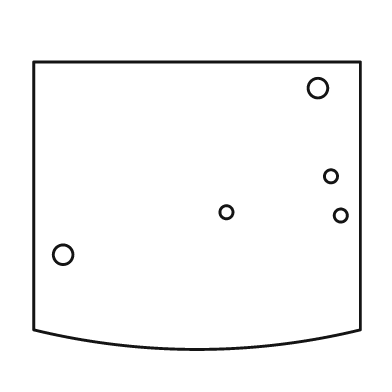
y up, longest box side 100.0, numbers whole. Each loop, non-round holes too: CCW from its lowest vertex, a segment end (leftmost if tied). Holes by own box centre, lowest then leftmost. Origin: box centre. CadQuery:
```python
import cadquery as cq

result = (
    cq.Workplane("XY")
    .moveTo(-50.0, -38.0)
    .threePointArc((0.0, -44.0), (50.0, -38.0))
    .lineTo(50.0, 44.0)
    .lineTo(-50.0, 44.0)
    .close()
    .moveTo(-41.0, -15.0)
    .circle(3.0)
    .moveTo(44.0, -3.0)
    .circle(2.0)
    .moveTo(9.0, -2.0)
    .circle(2.0)
    .moveTo(41.0, 9.0)
    .circle(2.0)
    .moveTo(37.0, 36.0)
    .circle(3.0)
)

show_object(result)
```